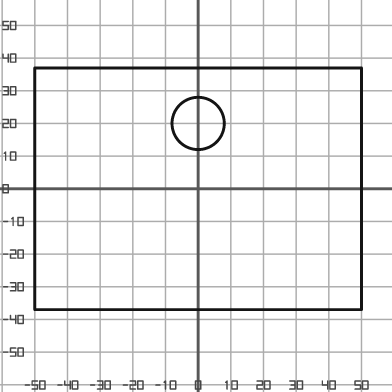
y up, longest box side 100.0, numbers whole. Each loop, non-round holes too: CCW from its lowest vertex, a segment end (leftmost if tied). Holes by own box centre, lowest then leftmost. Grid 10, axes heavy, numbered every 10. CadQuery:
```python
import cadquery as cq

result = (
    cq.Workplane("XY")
    .moveTo(-50.0, -37.0)
    .lineTo(50.0, -37.0)
    .lineTo(50.0, 37.0)
    .lineTo(-50.0, 37.0)
    .close()
    .moveTo(0.0, 20.0)
    .circle(8.0)
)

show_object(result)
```